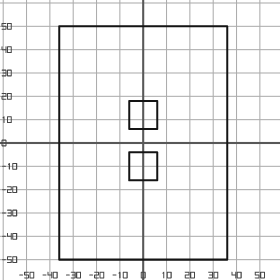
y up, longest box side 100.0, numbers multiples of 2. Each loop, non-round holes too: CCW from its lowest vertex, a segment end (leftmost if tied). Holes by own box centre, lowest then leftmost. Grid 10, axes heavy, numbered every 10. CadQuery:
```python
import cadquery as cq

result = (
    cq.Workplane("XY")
    .moveTo(-36.0, -50.0)
    .lineTo(36.0, -50.0)
    .lineTo(36.0, 50.0)
    .lineTo(-36.0, 50.0)
    .close()
    .moveTo(-6.0, -16.0)
    .lineTo(6.0, -16.0)
    .lineTo(6.0, -4.0)
    .lineTo(-6.0, -4.0)
    .close()
    .moveTo(-6.0, 6.0)
    .lineTo(6.0, 6.0)
    .lineTo(6.0, 18.0)
    .lineTo(-6.0, 18.0)
    .close()
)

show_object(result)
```